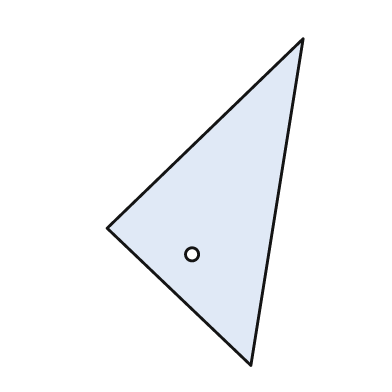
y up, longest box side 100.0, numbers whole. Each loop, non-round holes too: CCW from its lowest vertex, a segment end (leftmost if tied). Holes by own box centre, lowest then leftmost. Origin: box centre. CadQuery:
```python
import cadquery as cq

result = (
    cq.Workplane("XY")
    .moveTo(14.0, -50.0)
    .lineTo(30.0, 50.0)
    .lineTo(-30.0, -8.0)
    .close()
    .moveTo(-4.0, -16.0)
    .circle(2.0)
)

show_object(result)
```